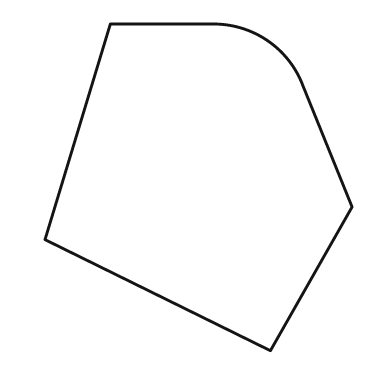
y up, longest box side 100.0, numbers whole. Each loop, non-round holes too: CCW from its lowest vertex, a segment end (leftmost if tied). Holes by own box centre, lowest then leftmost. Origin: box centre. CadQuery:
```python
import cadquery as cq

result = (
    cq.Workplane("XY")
    .moveTo(22.0, -50.0)
    .lineTo(47.0, -6.0)
    .lineTo(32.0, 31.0)
    .threePointArc((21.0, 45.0), (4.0, 50.0))
    .lineTo(-27.0, 50.0)
    .lineTo(-47.0, -16.0)
    .close()
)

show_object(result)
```